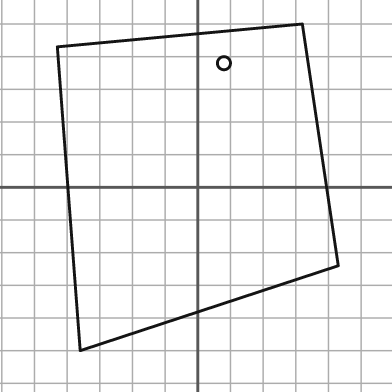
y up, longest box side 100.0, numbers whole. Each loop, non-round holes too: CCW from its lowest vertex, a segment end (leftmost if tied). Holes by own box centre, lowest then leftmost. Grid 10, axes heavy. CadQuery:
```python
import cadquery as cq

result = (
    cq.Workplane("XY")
    .moveTo(-36.0, -50.0)
    .lineTo(43.0, -24.0)
    .lineTo(32.0, 50.0)
    .lineTo(-43.0, 43.0)
    .close()
    .moveTo(8.0, 38.0)
    .circle(2.0)
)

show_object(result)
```